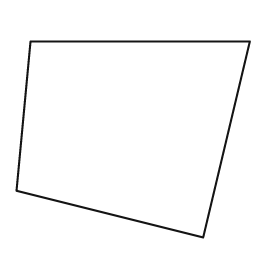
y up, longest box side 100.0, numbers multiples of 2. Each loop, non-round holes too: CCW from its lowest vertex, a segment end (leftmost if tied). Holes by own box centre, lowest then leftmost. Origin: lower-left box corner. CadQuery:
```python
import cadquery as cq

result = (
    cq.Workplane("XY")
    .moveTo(80.0, 0.0)
    .lineTo(100.0, 84.0)
    .lineTo(6.0, 84.0)
    .lineTo(0.0, 20.0)
    .close()
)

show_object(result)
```